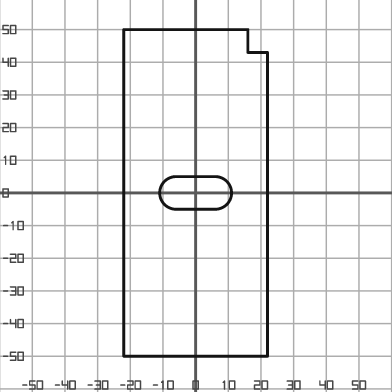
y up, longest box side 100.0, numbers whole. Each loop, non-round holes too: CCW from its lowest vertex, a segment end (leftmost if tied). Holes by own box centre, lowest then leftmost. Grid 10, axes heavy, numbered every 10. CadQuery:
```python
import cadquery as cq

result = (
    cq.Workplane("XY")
    .moveTo(-22.0, -50.0)
    .lineTo(22.0, -50.0)
    .lineTo(22.0, 43.0)
    .lineTo(16.0, 43.0)
    .lineTo(16.0, 50.0)
    .lineTo(-22.0, 50.0)
    .close()
    .moveTo(-6.0, -5.0)
    .lineTo(6.0, -5.0)
    .threePointArc((11.0, 0.0), (6.0, 5.0))
    .lineTo(-6.0, 5.0)
    .threePointArc((-11.0, 0.0), (-6.0, -5.0))
    .close()
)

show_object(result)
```